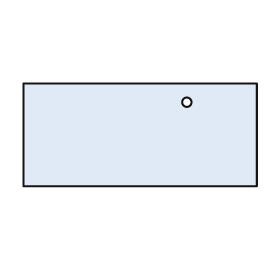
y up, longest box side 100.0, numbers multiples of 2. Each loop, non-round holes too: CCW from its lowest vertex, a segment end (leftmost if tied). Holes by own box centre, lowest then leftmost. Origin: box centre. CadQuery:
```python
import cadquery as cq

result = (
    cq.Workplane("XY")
    .moveTo(-50.0, -22.0)
    .lineTo(50.0, -22.0)
    .lineTo(50.0, 22.0)
    .lineTo(-50.0, 22.0)
    .close()
    .moveTo(20.0, 14.0)
    .circle(2.0)
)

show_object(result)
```